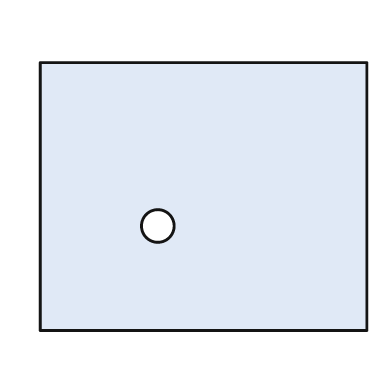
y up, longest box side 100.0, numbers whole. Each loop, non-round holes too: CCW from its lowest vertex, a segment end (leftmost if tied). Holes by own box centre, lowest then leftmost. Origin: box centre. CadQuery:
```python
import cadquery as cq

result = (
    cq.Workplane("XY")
    .moveTo(-50.0, -41.0)
    .lineTo(50.0, -41.0)
    .lineTo(50.0, 41.0)
    .lineTo(-50.0, 41.0)
    .close()
    .moveTo(-14.0, -9.0)
    .circle(5.0)
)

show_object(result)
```